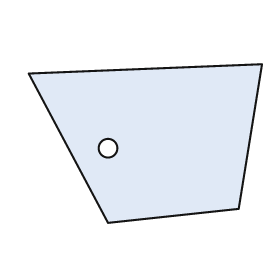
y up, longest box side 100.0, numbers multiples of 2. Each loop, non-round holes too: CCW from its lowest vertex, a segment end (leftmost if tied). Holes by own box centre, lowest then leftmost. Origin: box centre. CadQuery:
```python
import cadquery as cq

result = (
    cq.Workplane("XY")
    .moveTo(-16.0, -34.0)
    .lineTo(40.0, -28.0)
    .lineTo(50.0, 34.0)
    .lineTo(-50.0, 30.0)
    .close()
    .moveTo(-16.0, -2.0)
    .circle(4.0)
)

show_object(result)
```